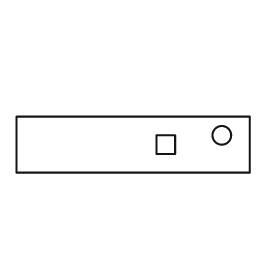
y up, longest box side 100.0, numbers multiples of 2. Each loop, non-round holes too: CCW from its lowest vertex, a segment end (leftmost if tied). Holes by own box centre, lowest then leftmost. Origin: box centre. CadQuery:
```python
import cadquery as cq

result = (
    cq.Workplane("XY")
    .moveTo(-50.0, -12.0)
    .lineTo(50.0, -12.0)
    .lineTo(50.0, 12.0)
    .lineTo(-50.0, 12.0)
    .close()
    .moveTo(10.0, -4.0)
    .lineTo(18.0, -4.0)
    .lineTo(18.0, 4.0)
    .lineTo(10.0, 4.0)
    .close()
    .moveTo(38.0, 4.0)
    .circle(4.0)
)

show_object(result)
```